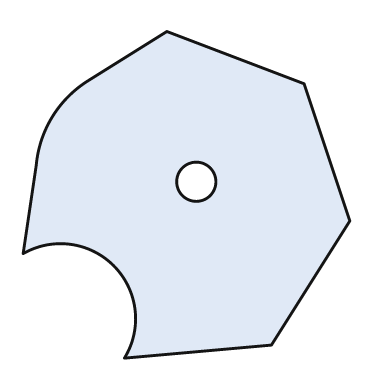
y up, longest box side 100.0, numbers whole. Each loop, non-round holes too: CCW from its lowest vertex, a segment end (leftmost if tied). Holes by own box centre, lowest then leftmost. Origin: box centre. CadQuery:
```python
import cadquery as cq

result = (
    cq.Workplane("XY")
    .moveTo(-19.0, -50.0)
    .lineTo(26.0, -46.0)
    .lineTo(50.0, -8.0)
    .lineTo(36.0, 34.0)
    .lineTo(-6.0, 50.0)
    .lineTo(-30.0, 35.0)
    .threePointArc((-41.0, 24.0), (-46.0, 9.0))
    .lineTo(-50.0, -18.0)
    .threePointArc((-22.0, -22.0), (-19.0, -50.0))
    .close()
    .moveTo(3.0, 4.0)
    .circle(6.0)
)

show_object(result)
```